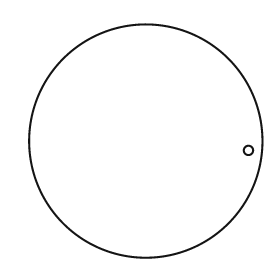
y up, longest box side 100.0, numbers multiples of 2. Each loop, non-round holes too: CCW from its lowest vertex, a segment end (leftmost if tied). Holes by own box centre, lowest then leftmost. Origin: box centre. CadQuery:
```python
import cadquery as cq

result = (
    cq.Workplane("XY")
    .moveTo(0.0, 0.0)
    .circle(50.0)
    .moveTo(44.0, -4.0)
    .circle(2.0)
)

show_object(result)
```